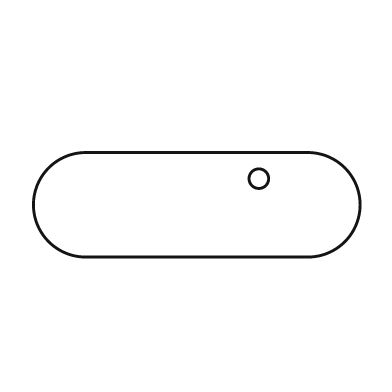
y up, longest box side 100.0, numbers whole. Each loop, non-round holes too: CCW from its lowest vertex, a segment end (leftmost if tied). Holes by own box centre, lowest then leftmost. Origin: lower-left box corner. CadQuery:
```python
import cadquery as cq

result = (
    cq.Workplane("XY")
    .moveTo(16.0, 0.0)
    .lineTo(84.0, 0.0)
    .threePointArc((100.0, 16.0), (84.0, 32.0))
    .lineTo(16.0, 32.0)
    .threePointArc((0.0, 16.0), (16.0, 0.0))
    .close()
    .moveTo(69.0, 24.0)
    .circle(3.0)
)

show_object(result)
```